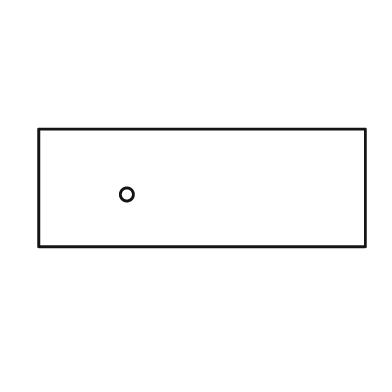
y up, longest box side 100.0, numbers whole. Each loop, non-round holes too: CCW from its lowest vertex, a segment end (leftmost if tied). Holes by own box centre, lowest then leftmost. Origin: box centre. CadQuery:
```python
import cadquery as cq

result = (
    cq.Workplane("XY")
    .moveTo(-50.0, -18.0)
    .lineTo(50.0, -18.0)
    .lineTo(50.0, 18.0)
    .lineTo(-50.0, 18.0)
    .close()
    .moveTo(-23.0, -2.0)
    .circle(2.0)
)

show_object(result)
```